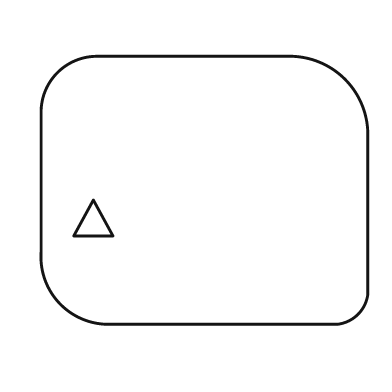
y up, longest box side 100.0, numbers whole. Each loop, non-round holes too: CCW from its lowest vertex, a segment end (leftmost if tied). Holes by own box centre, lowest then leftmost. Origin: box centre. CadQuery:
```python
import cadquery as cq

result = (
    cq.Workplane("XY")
    .moveTo(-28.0, -41.0)
    .lineTo(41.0, -41.0)
    .threePointArc((47.0, -38.0), (50.0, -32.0))
    .lineTo(50.0, 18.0)
    .threePointArc((43.0, 34.0), (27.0, 41.0))
    .lineTo(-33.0, 41.0)
    .threePointArc((-45.0, 36.0), (-50.0, 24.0))
    .lineTo(-50.0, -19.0)
    .threePointArc((-44.0, -35.0), (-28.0, -41.0))
    .close()
    .moveTo(-40.0, -14.0)
    .lineTo(-28.0, -14.0)
    .lineTo(-34.0, -3.0)
    .close()
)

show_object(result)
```